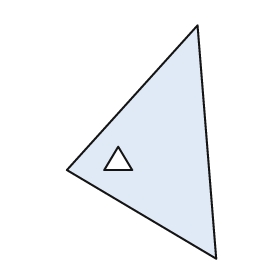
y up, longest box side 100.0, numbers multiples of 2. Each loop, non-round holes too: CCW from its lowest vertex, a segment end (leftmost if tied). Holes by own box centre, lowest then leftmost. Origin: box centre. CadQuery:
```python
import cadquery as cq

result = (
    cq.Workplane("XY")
    .moveTo(32.0, -50.0)
    .lineTo(24.0, 50.0)
    .lineTo(-32.0, -12.0)
    .close()
    .moveTo(-16.0, -12.0)
    .lineTo(-4.0, -12.0)
    .lineTo(-10.0, -2.0)
    .close()
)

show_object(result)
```